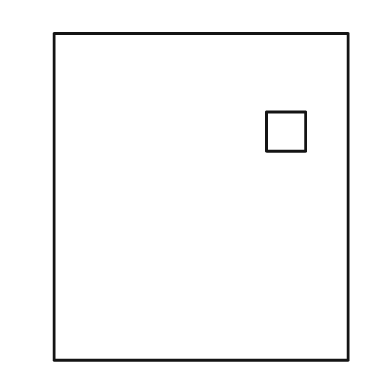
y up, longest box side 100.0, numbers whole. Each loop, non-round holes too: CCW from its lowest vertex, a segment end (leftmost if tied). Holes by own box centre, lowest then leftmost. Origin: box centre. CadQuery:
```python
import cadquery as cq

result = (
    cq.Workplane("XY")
    .moveTo(-45.0, -50.0)
    .lineTo(45.0, -50.0)
    .lineTo(45.0, 50.0)
    .lineTo(-45.0, 50.0)
    .close()
    .moveTo(20.0, 14.0)
    .lineTo(32.0, 14.0)
    .lineTo(32.0, 26.0)
    .lineTo(20.0, 26.0)
    .close()
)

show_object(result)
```